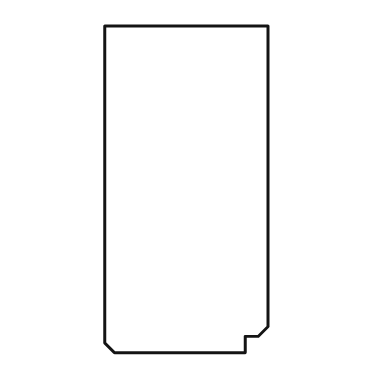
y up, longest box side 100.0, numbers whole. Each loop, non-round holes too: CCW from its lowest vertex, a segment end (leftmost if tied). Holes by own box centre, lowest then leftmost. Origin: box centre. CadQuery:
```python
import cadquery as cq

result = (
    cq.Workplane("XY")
    .moveTo(-22.0, -50.0)
    .lineTo(18.0, -50.0)
    .lineTo(18.0, -45.0)
    .lineTo(22.0, -45.0)
    .lineTo(25.0, -42.0)
    .lineTo(25.0, 50.0)
    .lineTo(-25.0, 50.0)
    .lineTo(-25.0, -47.0)
    .close()
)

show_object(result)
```